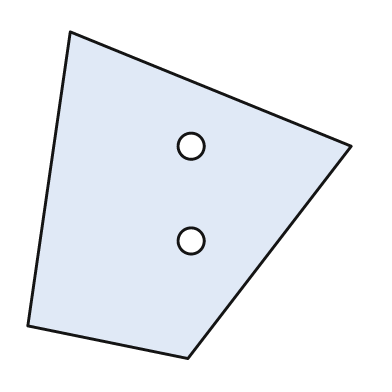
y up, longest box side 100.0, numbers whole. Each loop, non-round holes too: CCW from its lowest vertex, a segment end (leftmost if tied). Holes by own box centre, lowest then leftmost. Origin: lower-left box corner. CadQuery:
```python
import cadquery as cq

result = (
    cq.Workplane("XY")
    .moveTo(49.0, 0.0)
    .lineTo(99.0, 65.0)
    .lineTo(13.0, 100.0)
    .lineTo(0.0, 10.0)
    .close()
    .moveTo(50.0, 36.0)
    .circle(4.0)
    .moveTo(50.0, 65.0)
    .circle(4.0)
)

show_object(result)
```